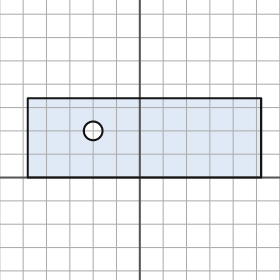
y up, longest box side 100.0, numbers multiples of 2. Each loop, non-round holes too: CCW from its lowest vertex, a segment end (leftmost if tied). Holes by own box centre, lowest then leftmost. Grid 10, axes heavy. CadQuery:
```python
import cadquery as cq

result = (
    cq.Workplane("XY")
    .moveTo(-48.0, 0.0)
    .lineTo(52.0, 0.0)
    .lineTo(52.0, 34.0)
    .lineTo(-48.0, 34.0)
    .close()
    .moveTo(-20.0, 20.0)
    .circle(4.0)
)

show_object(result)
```